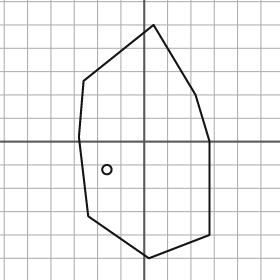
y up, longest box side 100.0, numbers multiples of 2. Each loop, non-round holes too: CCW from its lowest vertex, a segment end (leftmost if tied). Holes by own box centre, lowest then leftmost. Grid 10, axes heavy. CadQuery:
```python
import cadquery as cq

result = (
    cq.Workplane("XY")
    .moveTo(2.0, -50.0)
    .lineTo(28.0, -40.0)
    .lineTo(28.0, 0.0)
    .lineTo(22.0, 20.0)
    .lineTo(4.0, 50.0)
    .lineTo(-26.0, 26.0)
    .lineTo(-28.0, 2.0)
    .lineTo(-24.0, -32.0)
    .close()
    .moveTo(-16.0, -12.0)
    .circle(2.0)
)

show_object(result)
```